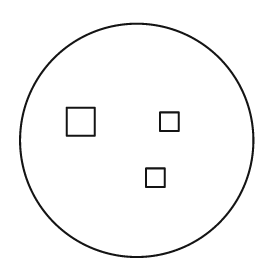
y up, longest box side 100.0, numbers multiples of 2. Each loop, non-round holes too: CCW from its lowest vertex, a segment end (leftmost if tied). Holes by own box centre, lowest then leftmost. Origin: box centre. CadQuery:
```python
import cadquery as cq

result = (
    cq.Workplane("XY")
    .moveTo(0.0, 0.0)
    .circle(50.0)
    .moveTo(4.0, -20.0)
    .lineTo(12.0, -20.0)
    .lineTo(12.0, -12.0)
    .lineTo(4.0, -12.0)
    .close()
    .moveTo(-30.0, 2.0)
    .lineTo(-18.0, 2.0)
    .lineTo(-18.0, 14.0)
    .lineTo(-30.0, 14.0)
    .close()
    .moveTo(10.0, 4.0)
    .lineTo(18.0, 4.0)
    .lineTo(18.0, 12.0)
    .lineTo(10.0, 12.0)
    .close()
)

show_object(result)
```